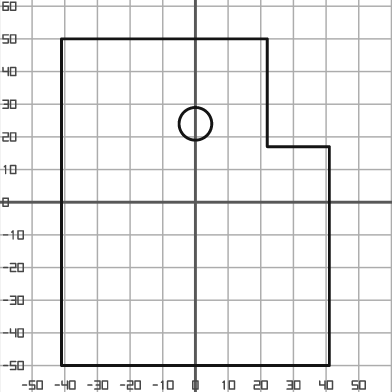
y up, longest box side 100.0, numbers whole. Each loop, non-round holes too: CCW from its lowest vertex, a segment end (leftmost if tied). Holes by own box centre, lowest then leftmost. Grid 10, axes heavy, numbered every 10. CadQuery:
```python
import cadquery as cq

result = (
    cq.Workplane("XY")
    .moveTo(-41.0, -50.0)
    .lineTo(41.0, -50.0)
    .lineTo(41.0, 17.0)
    .lineTo(22.0, 17.0)
    .lineTo(22.0, 50.0)
    .lineTo(-41.0, 50.0)
    .close()
    .moveTo(0.0, 24.0)
    .circle(5.0)
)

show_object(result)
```